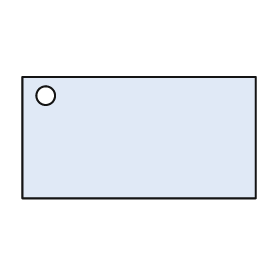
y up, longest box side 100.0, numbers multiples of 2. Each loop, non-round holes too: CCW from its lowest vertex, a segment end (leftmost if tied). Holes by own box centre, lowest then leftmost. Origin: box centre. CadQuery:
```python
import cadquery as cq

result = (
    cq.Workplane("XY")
    .moveTo(-50.0, -26.0)
    .lineTo(50.0, -26.0)
    .lineTo(50.0, 26.0)
    .lineTo(-50.0, 26.0)
    .close()
    .moveTo(-40.0, 18.0)
    .circle(4.0)
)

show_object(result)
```